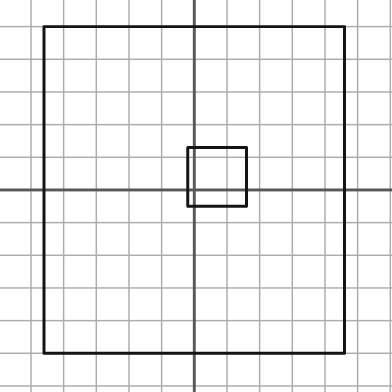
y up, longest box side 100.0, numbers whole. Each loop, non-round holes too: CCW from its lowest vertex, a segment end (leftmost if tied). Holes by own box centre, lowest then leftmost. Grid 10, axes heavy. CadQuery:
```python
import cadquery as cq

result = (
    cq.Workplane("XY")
    .moveTo(-46.0, -50.0)
    .lineTo(46.0, -50.0)
    .lineTo(46.0, 50.0)
    .lineTo(-46.0, 50.0)
    .close()
    .moveTo(-2.0, -5.0)
    .lineTo(16.0, -5.0)
    .lineTo(16.0, 13.0)
    .lineTo(-2.0, 13.0)
    .close()
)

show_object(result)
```